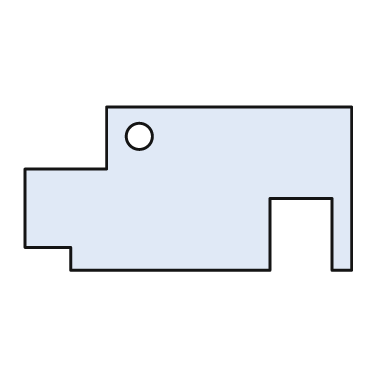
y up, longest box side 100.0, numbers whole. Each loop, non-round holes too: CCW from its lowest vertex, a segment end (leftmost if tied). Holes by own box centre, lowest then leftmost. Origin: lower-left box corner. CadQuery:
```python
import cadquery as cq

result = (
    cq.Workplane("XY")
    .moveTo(14.0, 0.0)
    .lineTo(75.0, 0.0)
    .lineTo(75.0, 22.0)
    .lineTo(94.0, 22.0)
    .lineTo(94.0, 0.0)
    .lineTo(100.0, 0.0)
    .lineTo(100.0, 50.0)
    .lineTo(25.0, 50.0)
    .lineTo(25.0, 31.0)
    .lineTo(0.0, 31.0)
    .lineTo(0.0, 7.0)
    .lineTo(14.0, 7.0)
    .close()
    .moveTo(35.0, 41.0)
    .circle(4.0)
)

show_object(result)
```